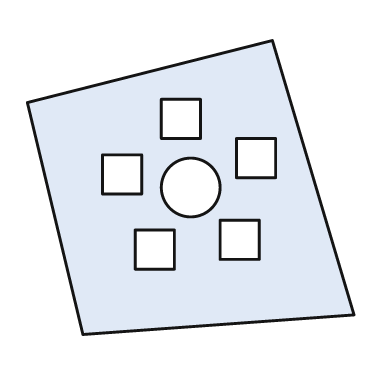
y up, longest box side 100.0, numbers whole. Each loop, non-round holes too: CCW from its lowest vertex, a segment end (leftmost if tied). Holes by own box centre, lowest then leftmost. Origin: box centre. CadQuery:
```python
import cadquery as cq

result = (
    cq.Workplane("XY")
    .moveTo(-33.0, -45.0)
    .lineTo(50.0, -39.0)
    .lineTo(25.0, 45.0)
    .lineTo(-50.0, 26.0)
    .close()
    .moveTo(-17.0, -25.0)
    .lineTo(-5.0, -25.0)
    .lineTo(-5.0, -13.0)
    .lineTo(-17.0, -13.0)
    .close()
    .moveTo(9.0, -22.0)
    .lineTo(21.0, -22.0)
    .lineTo(21.0, -10.0)
    .lineTo(9.0, -10.0)
    .close()
    .moveTo(0.0, 0.0)
    .circle(9.0)
    .moveTo(-27.0, -2.0)
    .lineTo(-15.0, -2.0)
    .lineTo(-15.0, 10.0)
    .lineTo(-27.0, 10.0)
    .close()
    .moveTo(14.0, 3.0)
    .lineTo(26.0, 3.0)
    .lineTo(26.0, 15.0)
    .lineTo(14.0, 15.0)
    .close()
    .moveTo(-9.0, 15.0)
    .lineTo(3.0, 15.0)
    .lineTo(3.0, 27.0)
    .lineTo(-9.0, 27.0)
    .close()
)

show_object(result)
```